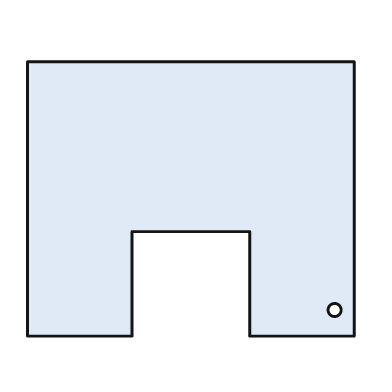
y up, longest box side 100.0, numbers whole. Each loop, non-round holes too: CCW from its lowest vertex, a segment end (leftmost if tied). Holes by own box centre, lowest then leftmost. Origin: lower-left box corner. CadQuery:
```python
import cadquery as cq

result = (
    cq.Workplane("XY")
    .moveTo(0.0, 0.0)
    .lineTo(32.0, 0.0)
    .lineTo(32.0, 32.0)
    .lineTo(68.0, 32.0)
    .lineTo(68.0, 0.0)
    .lineTo(100.0, 0.0)
    .lineTo(100.0, 84.0)
    .lineTo(0.0, 84.0)
    .close()
    .moveTo(94.0, 8.0)
    .circle(2.0)
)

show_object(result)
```